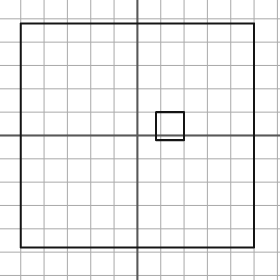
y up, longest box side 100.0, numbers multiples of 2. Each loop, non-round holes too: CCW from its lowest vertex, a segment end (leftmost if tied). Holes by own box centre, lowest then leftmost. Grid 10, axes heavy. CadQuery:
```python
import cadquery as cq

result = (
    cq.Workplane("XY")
    .moveTo(-50.0, -48.0)
    .lineTo(50.0, -48.0)
    .lineTo(50.0, 48.0)
    .lineTo(-50.0, 48.0)
    .close()
    .moveTo(8.0, -2.0)
    .lineTo(20.0, -2.0)
    .lineTo(20.0, 10.0)
    .lineTo(8.0, 10.0)
    .close()
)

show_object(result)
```